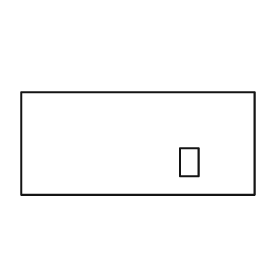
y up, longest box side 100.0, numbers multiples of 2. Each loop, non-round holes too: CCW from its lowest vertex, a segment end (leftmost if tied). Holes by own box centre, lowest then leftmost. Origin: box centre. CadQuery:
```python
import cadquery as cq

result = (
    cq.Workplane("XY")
    .moveTo(-50.0, -22.0)
    .lineTo(50.0, -22.0)
    .lineTo(50.0, 22.0)
    .lineTo(-50.0, 22.0)
    .close()
    .moveTo(18.0, -14.0)
    .lineTo(26.0, -14.0)
    .lineTo(26.0, -2.0)
    .lineTo(18.0, -2.0)
    .close()
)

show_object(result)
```